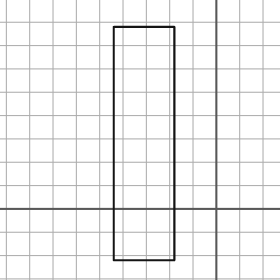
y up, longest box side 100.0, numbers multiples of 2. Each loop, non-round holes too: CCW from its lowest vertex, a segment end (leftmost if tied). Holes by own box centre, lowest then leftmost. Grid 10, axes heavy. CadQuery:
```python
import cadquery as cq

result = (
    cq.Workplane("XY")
    .moveTo(-44.0, -22.0)
    .lineTo(-18.0, -22.0)
    .lineTo(-18.0, 78.0)
    .lineTo(-44.0, 78.0)
    .close()
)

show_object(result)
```